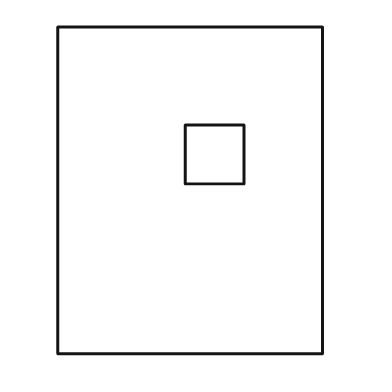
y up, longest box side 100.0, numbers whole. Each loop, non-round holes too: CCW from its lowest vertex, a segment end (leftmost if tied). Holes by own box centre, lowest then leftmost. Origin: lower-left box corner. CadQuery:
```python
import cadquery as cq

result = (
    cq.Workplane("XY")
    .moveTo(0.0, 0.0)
    .lineTo(81.0, 0.0)
    .lineTo(81.0, 100.0)
    .lineTo(0.0, 100.0)
    .close()
    .moveTo(39.0, 52.0)
    .lineTo(57.0, 52.0)
    .lineTo(57.0, 70.0)
    .lineTo(39.0, 70.0)
    .close()
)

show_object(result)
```